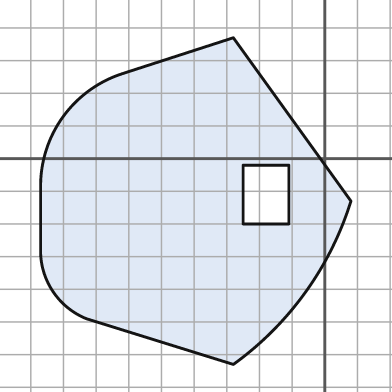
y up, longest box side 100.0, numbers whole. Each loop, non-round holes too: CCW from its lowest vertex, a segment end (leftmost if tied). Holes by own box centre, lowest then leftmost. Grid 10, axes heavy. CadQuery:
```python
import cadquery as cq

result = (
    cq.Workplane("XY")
    .moveTo(-28.0, -63.0)
    .threePointArc((-6.0, -41.0), (8.0, -13.0))
    .lineTo(-28.0, 37.0)
    .lineTo(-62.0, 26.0)
    .threePointArc((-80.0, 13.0), (-87.0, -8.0))
    .lineTo(-87.0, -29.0)
    .threePointArc((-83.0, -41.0), (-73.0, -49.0))
    .close()
    .moveTo(-25.0, -20.0)
    .lineTo(-11.0, -20.0)
    .lineTo(-11.0, -2.0)
    .lineTo(-25.0, -2.0)
    .close()
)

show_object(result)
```